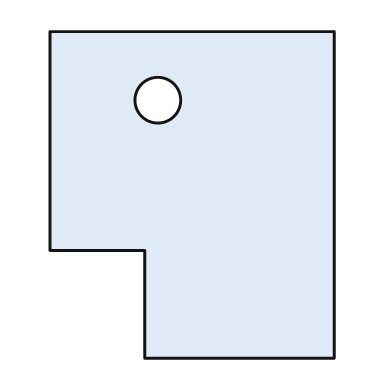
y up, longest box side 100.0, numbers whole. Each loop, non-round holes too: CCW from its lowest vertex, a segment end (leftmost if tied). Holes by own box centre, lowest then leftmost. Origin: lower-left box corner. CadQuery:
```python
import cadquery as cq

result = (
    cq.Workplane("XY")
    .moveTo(29.0, 0.0)
    .lineTo(87.0, 0.0)
    .lineTo(87.0, 100.0)
    .lineTo(0.0, 100.0)
    .lineTo(0.0, 33.0)
    .lineTo(29.0, 33.0)
    .close()
    .moveTo(33.0, 79.0)
    .circle(7.0)
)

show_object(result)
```